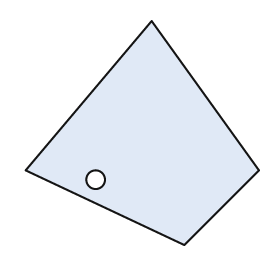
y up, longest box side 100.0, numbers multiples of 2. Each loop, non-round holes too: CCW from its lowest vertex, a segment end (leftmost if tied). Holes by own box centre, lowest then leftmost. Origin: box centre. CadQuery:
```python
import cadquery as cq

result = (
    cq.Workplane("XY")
    .moveTo(18.0, -48.0)
    .lineTo(50.0, -16.0)
    .lineTo(4.0, 48.0)
    .lineTo(-50.0, -16.0)
    .close()
    .moveTo(-20.0, -20.0)
    .circle(4.0)
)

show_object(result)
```